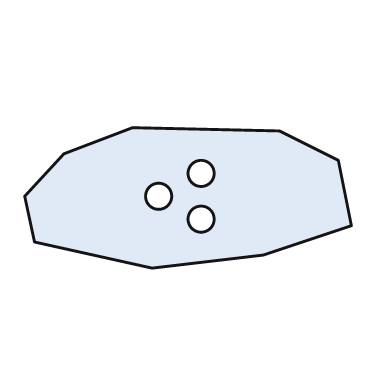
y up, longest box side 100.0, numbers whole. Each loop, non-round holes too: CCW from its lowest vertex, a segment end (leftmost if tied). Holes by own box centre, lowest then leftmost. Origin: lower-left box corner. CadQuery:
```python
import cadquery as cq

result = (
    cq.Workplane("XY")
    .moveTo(39.0, 0.0)
    .lineTo(73.0, 4.0)
    .lineTo(100.0, 13.0)
    .lineTo(96.0, 33.0)
    .lineTo(78.0, 42.0)
    .lineTo(33.0, 43.0)
    .lineTo(12.0, 35.0)
    .lineTo(0.0, 22.0)
    .lineTo(3.0, 8.0)
    .close()
    .moveTo(54.0, 15.0)
    .circle(4.0)
    .moveTo(41.0, 22.0)
    .circle(4.0)
    .moveTo(54.0, 29.0)
    .circle(4.0)
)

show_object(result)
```